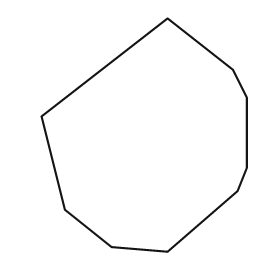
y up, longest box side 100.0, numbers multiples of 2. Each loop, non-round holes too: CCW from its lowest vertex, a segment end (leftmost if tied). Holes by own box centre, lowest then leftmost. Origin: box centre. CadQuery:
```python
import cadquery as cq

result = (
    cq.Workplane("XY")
    .moveTo(10.0, -50.0)
    .lineTo(40.0, -24.0)
    .lineTo(44.0, -14.0)
    .lineTo(44.0, 16.0)
    .lineTo(38.0, 28.0)
    .lineTo(10.0, 50.0)
    .lineTo(-44.0, 8.0)
    .lineTo(-34.0, -32.0)
    .lineTo(-14.0, -48.0)
    .close()
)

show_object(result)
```